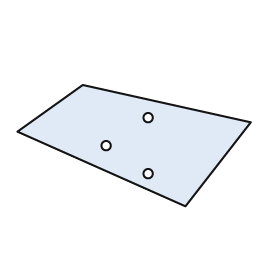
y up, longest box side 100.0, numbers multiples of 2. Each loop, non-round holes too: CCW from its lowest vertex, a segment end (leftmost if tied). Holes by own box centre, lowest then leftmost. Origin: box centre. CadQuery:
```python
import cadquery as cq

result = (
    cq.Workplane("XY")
    .moveTo(22.0, -26.0)
    .lineTo(50.0, 10.0)
    .lineTo(-22.0, 26.0)
    .lineTo(-50.0, 6.0)
    .close()
    .moveTo(6.0, -12.0)
    .circle(2.0)
    .moveTo(-12.0, 0.0)
    .circle(2.0)
    .moveTo(6.0, 12.0)
    .circle(2.0)
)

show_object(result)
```